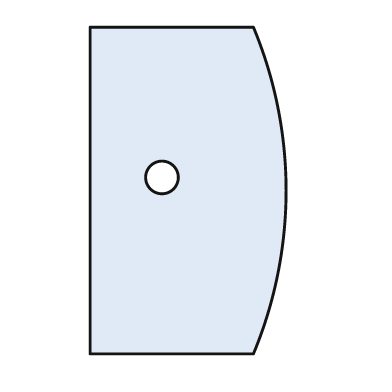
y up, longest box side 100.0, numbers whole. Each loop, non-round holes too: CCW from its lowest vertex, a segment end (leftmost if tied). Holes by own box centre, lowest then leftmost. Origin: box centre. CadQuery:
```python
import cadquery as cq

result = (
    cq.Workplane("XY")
    .moveTo(-30.0, -50.0)
    .lineTo(20.0, -50.0)
    .threePointArc((30.0, 0.0), (20.0, 50.0))
    .lineTo(-30.0, 50.0)
    .close()
    .moveTo(-8.0, 4.0)
    .circle(5.0)
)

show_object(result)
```